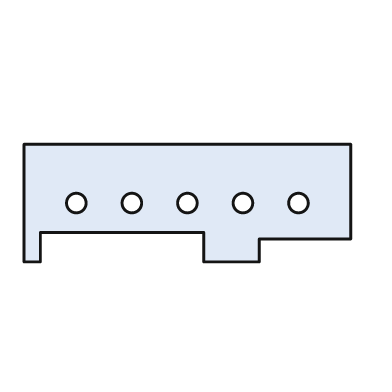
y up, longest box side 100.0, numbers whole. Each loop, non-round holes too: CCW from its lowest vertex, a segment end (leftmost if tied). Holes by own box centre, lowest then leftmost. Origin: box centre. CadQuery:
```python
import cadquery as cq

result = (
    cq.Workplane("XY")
    .moveTo(-50.0, -18.0)
    .lineTo(-45.0, -18.0)
    .lineTo(-45.0, -9.0)
    .lineTo(5.0, -9.0)
    .lineTo(5.0, -18.0)
    .lineTo(22.0, -18.0)
    .lineTo(22.0, -11.0)
    .lineTo(50.0, -11.0)
    .lineTo(50.0, 18.0)
    .lineTo(-50.0, 18.0)
    .close()
    .moveTo(-34.0, 0.0)
    .circle(3.0)
    .moveTo(-17.0, 0.0)
    .circle(3.0)
    .moveTo(0.0, 0.0)
    .circle(3.0)
    .moveTo(17.0, 0.0)
    .circle(3.0)
    .moveTo(34.0, 0.0)
    .circle(3.0)
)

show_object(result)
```